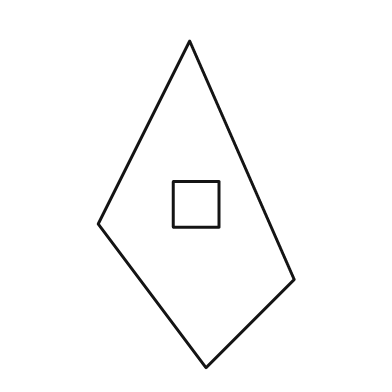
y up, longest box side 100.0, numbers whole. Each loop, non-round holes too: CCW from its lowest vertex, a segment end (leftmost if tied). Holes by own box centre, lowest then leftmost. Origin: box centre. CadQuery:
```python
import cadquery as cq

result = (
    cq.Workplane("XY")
    .moveTo(3.0, -50.0)
    .lineTo(30.0, -23.0)
    .lineTo(-2.0, 50.0)
    .lineTo(-30.0, -6.0)
    .close()
    .moveTo(-7.0, -7.0)
    .lineTo(7.0, -7.0)
    .lineTo(7.0, 7.0)
    .lineTo(-7.0, 7.0)
    .close()
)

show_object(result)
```